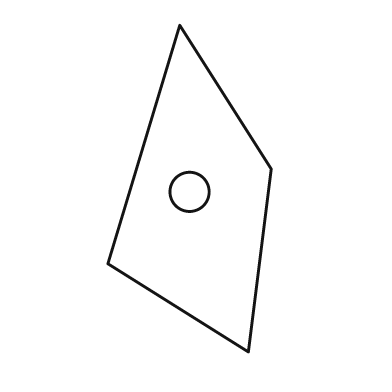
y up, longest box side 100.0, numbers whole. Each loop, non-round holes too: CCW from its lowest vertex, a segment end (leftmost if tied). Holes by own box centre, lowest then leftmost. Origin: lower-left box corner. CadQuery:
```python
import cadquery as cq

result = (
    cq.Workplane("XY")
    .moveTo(43.0, 0.0)
    .lineTo(50.0, 56.0)
    .lineTo(22.0, 100.0)
    .lineTo(0.0, 27.0)
    .close()
    .moveTo(25.0, 49.0)
    .circle(6.0)
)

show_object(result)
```